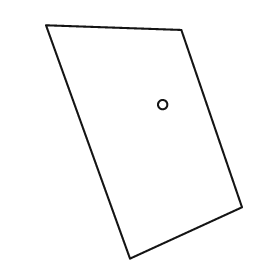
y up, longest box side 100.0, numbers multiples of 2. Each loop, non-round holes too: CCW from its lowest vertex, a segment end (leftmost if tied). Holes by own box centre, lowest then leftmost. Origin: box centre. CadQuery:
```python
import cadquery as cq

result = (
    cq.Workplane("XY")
    .moveTo(-6.0, -50.0)
    .lineTo(42.0, -28.0)
    .lineTo(16.0, 48.0)
    .lineTo(-42.0, 50.0)
    .close()
    .moveTo(8.0, 16.0)
    .circle(2.0)
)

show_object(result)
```